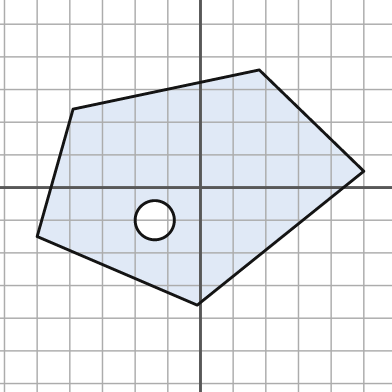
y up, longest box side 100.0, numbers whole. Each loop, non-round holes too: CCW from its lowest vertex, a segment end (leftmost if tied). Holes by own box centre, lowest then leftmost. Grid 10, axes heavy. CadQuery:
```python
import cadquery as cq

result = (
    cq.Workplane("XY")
    .moveTo(-1.0, -36.0)
    .lineTo(50.0, 5.0)
    .lineTo(18.0, 36.0)
    .lineTo(-39.0, 24.0)
    .lineTo(-50.0, -15.0)
    .close()
    .moveTo(-14.0, -10.0)
    .circle(6.0)
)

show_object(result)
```